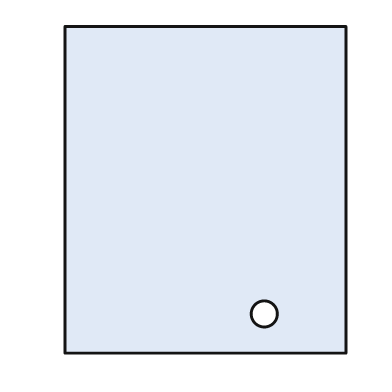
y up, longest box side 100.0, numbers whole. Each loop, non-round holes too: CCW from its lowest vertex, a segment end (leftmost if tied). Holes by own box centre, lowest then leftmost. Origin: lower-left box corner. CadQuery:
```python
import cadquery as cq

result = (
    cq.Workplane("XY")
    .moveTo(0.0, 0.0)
    .lineTo(86.0, 0.0)
    .lineTo(86.0, 100.0)
    .lineTo(0.0, 100.0)
    .close()
    .moveTo(61.0, 12.0)
    .circle(4.0)
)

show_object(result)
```